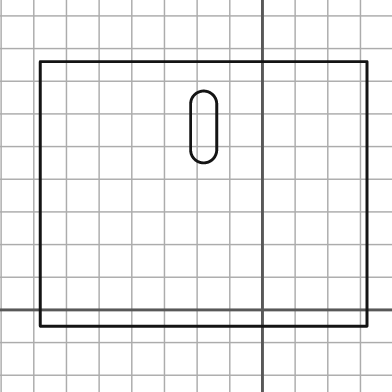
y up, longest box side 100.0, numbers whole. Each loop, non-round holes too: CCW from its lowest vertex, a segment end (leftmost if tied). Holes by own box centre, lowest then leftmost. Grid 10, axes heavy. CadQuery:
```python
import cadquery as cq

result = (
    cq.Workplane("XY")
    .moveTo(-68.0, -5.0)
    .lineTo(32.0, -5.0)
    .lineTo(32.0, 76.0)
    .lineTo(-68.0, 76.0)
    .close()
    .moveTo(-22.0, 49.0)
    .threePointArc((-18.0, 45.0), (-14.0, 49.0))
    .lineTo(-14.0, 63.0)
    .threePointArc((-18.0, 67.0), (-22.0, 63.0))
    .close()
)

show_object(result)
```